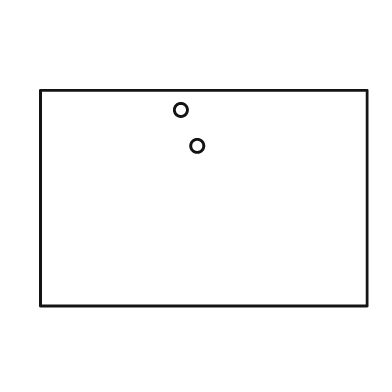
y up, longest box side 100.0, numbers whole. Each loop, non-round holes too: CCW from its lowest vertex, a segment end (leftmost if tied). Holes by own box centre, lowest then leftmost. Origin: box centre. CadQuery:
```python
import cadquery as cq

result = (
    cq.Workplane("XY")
    .moveTo(-50.0, -33.0)
    .lineTo(50.0, -33.0)
    .lineTo(50.0, 33.0)
    .lineTo(-50.0, 33.0)
    .close()
    .moveTo(-2.0, 16.0)
    .circle(2.0)
    .moveTo(-7.0, 27.0)
    .circle(2.0)
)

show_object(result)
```